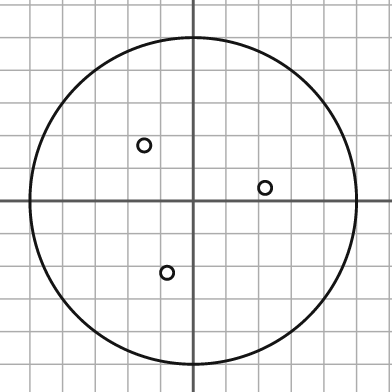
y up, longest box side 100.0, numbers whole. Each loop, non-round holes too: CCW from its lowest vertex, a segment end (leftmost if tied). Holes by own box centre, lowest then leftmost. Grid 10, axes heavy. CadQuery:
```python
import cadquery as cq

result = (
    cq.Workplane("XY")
    .moveTo(0.0, 0.0)
    .circle(50.0)
    .moveTo(-8.0, -22.0)
    .circle(2.0)
    .moveTo(22.0, 4.0)
    .circle(2.0)
    .moveTo(-15.0, 17.0)
    .circle(2.0)
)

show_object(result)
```